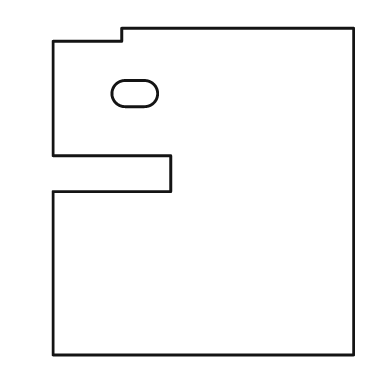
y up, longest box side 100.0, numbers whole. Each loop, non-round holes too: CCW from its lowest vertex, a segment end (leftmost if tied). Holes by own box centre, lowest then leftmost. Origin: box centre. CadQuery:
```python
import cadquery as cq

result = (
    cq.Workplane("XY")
    .moveTo(-46.0, -50.0)
    .lineTo(46.0, -50.0)
    .lineTo(46.0, 50.0)
    .lineTo(-25.0, 50.0)
    .lineTo(-25.0, 46.0)
    .lineTo(-46.0, 46.0)
    .lineTo(-46.0, 11.0)
    .lineTo(-10.0, 11.0)
    .lineTo(-10.0, 0.0)
    .lineTo(-46.0, 0.0)
    .close()
    .moveTo(-24.0, 26.0)
    .lineTo(-18.0, 26.0)
    .threePointArc((-14.0, 30.0), (-18.0, 34.0))
    .lineTo(-24.0, 34.0)
    .threePointArc((-28.0, 30.0), (-24.0, 26.0))
    .close()
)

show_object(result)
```